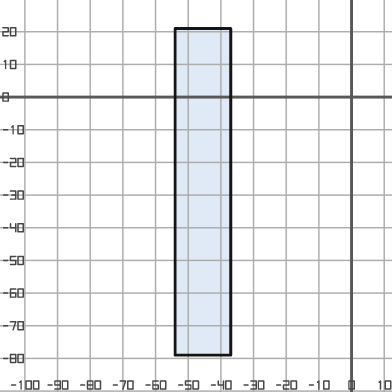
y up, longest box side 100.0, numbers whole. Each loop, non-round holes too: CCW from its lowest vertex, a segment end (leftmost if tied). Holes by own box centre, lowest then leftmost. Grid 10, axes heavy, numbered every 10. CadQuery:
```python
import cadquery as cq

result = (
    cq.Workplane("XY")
    .moveTo(-54.0, -79.0)
    .lineTo(-37.0, -79.0)
    .lineTo(-37.0, 21.0)
    .lineTo(-54.0, 21.0)
    .close()
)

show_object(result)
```